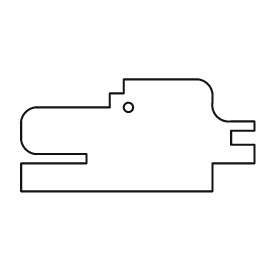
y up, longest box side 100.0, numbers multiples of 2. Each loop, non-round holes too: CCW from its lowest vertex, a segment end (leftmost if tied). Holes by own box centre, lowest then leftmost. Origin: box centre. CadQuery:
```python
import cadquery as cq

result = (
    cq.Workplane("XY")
    .moveTo(-50.0, -24.0)
    .lineTo(32.0, -24.0)
    .lineTo(32.0, -12.0)
    .lineTo(50.0, -12.0)
    .lineTo(50.0, -4.0)
    .lineTo(40.0, -4.0)
    .lineTo(40.0, 2.0)
    .lineTo(50.0, 2.0)
    .lineTo(50.0, 6.0)
    .lineTo(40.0, 6.0)
    .threePointArc((34.0, 8.0), (32.0, 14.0))
    .lineTo(32.0, 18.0)
    .threePointArc((30.0, 22.0), (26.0, 24.0))
    .lineTo(-6.0, 24.0)
    .lineTo(-6.0, 18.0)
    .lineTo(-12.0, 18.0)
    .lineTo(-12.0, 12.0)
    .lineTo(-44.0, 12.0)
    .threePointArc((-48.0, 10.0), (-50.0, 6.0))
    .lineTo(-50.0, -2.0)
    .threePointArc((-48.0, -6.0), (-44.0, -8.0))
    .lineTo(-22.0, -8.0)
    .lineTo(-22.0, -12.0)
    .lineTo(-50.0, -12.0)
    .close()
    .moveTo(-4.0, 12.0)
    .circle(2.0)
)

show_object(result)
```